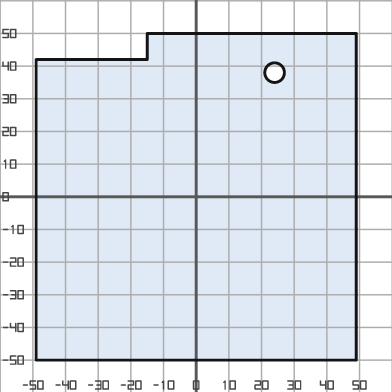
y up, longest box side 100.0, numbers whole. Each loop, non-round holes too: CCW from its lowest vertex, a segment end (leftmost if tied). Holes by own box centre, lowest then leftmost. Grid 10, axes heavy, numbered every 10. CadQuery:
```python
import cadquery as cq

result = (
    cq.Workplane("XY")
    .moveTo(-49.0, -50.0)
    .lineTo(49.0, -50.0)
    .lineTo(49.0, 50.0)
    .lineTo(-15.0, 50.0)
    .lineTo(-15.0, 42.0)
    .lineTo(-49.0, 42.0)
    .close()
    .moveTo(24.0, 38.0)
    .circle(3.0)
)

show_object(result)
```